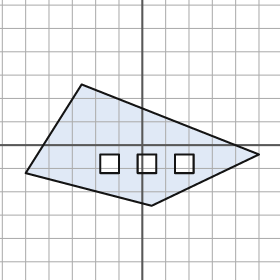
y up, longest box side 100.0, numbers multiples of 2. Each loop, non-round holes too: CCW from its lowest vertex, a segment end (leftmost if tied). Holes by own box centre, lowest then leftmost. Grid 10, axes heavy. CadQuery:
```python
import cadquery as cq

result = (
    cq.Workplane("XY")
    .moveTo(4.0, -26.0)
    .lineTo(50.0, -4.0)
    .lineTo(-26.0, 26.0)
    .lineTo(-50.0, -12.0)
    .close()
    .moveTo(-18.0, -12.0)
    .lineTo(-10.0, -12.0)
    .lineTo(-10.0, -4.0)
    .lineTo(-18.0, -4.0)
    .close()
    .moveTo(-2.0, -12.0)
    .lineTo(6.0, -12.0)
    .lineTo(6.0, -4.0)
    .lineTo(-2.0, -4.0)
    .close()
    .moveTo(14.0, -12.0)
    .lineTo(22.0, -12.0)
    .lineTo(22.0, -4.0)
    .lineTo(14.0, -4.0)
    .close()
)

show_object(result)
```